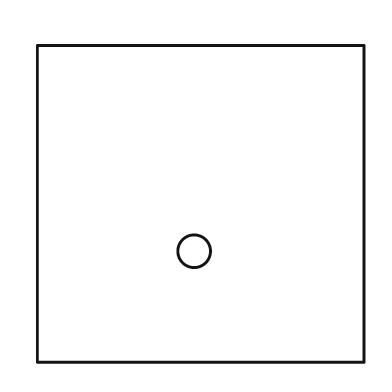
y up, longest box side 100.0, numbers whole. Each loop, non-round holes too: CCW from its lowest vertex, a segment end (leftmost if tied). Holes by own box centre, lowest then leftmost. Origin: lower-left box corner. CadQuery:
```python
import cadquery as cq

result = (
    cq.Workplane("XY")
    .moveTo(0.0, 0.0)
    .lineTo(100.0, 0.0)
    .lineTo(100.0, 97.0)
    .lineTo(0.0, 97.0)
    .close()
    .moveTo(48.0, 34.0)
    .circle(5.0)
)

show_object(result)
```